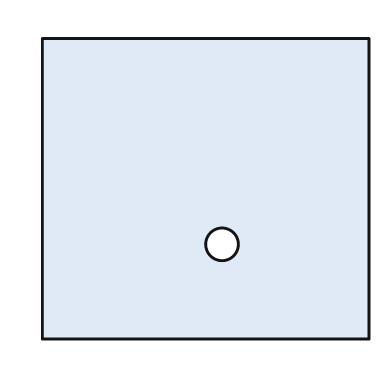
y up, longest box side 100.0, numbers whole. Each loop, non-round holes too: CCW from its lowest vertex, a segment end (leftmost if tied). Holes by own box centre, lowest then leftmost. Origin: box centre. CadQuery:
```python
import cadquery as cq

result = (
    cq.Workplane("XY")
    .moveTo(-50.0, -46.0)
    .lineTo(50.0, -46.0)
    .lineTo(50.0, 46.0)
    .lineTo(-50.0, 46.0)
    .close()
    .moveTo(5.0, -17.0)
    .circle(5.0)
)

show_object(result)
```